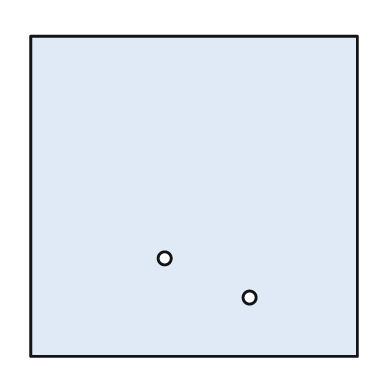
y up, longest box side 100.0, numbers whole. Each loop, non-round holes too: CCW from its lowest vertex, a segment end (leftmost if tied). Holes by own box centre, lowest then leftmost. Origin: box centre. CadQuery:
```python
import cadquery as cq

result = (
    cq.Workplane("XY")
    .moveTo(-50.0, -49.0)
    .lineTo(50.0, -49.0)
    .lineTo(50.0, 49.0)
    .lineTo(-50.0, 49.0)
    .close()
    .moveTo(17.0, -31.0)
    .circle(2.0)
    .moveTo(-9.0, -19.0)
    .circle(2.0)
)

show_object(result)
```